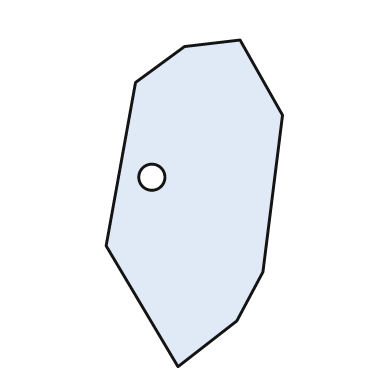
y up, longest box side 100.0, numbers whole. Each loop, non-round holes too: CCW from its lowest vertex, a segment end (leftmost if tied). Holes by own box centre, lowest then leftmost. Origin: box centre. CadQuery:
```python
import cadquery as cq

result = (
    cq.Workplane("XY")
    .moveTo(-5.0, -50.0)
    .lineTo(13.0, -36.0)
    .lineTo(21.0, -21.0)
    .lineTo(27.0, 27.0)
    .lineTo(14.0, 50.0)
    .lineTo(-3.0, 48.0)
    .lineTo(-18.0, 37.0)
    .lineTo(-27.0, -13.0)
    .close()
    .moveTo(-13.0, 8.0)
    .circle(4.0)
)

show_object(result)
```